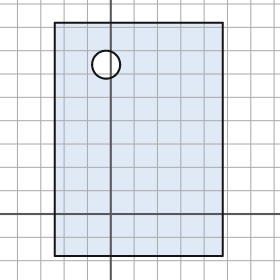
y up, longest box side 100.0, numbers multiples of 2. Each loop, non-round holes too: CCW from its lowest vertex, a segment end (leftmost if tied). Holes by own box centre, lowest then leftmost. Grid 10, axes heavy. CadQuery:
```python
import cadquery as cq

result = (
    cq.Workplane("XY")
    .moveTo(-24.0, -18.0)
    .lineTo(48.0, -18.0)
    .lineTo(48.0, 82.0)
    .lineTo(-24.0, 82.0)
    .close()
    .moveTo(-2.0, 64.0)
    .circle(6.0)
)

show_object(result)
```